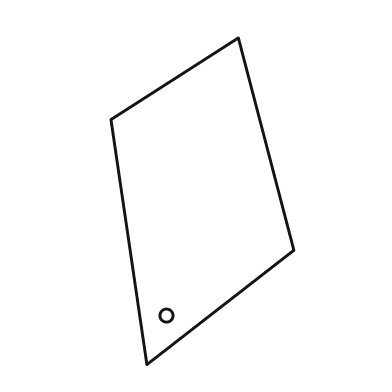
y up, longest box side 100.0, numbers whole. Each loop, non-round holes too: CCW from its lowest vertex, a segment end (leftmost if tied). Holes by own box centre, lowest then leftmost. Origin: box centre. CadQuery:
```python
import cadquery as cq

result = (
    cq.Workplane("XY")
    .moveTo(-17.0, -50.0)
    .lineTo(28.0, -15.0)
    .lineTo(11.0, 50.0)
    .lineTo(-28.0, 25.0)
    .close()
    .moveTo(-11.0, -35.0)
    .circle(2.0)
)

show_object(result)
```